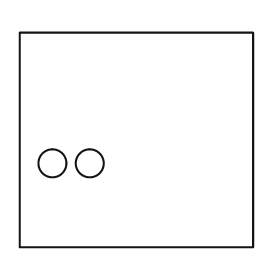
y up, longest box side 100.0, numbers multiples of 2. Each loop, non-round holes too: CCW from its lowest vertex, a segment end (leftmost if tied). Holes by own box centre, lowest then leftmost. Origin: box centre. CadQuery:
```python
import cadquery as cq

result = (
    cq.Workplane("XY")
    .moveTo(-50.0, -46.0)
    .lineTo(50.0, -46.0)
    .lineTo(50.0, 46.0)
    .lineTo(-50.0, 46.0)
    .close()
    .moveTo(-36.0, -10.0)
    .circle(6.0)
    .moveTo(-20.0, -10.0)
    .circle(6.0)
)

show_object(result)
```